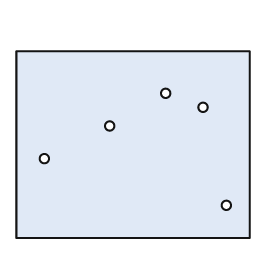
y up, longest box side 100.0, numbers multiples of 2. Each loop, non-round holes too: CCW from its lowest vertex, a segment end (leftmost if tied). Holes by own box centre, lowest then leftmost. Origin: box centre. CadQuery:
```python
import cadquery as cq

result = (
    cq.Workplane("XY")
    .moveTo(-50.0, -40.0)
    .lineTo(50.0, -40.0)
    .lineTo(50.0, 40.0)
    .lineTo(-50.0, 40.0)
    .close()
    .moveTo(40.0, -26.0)
    .circle(2.0)
    .moveTo(-38.0, -6.0)
    .circle(2.0)
    .moveTo(-10.0, 8.0)
    .circle(2.0)
    .moveTo(30.0, 16.0)
    .circle(2.0)
    .moveTo(14.0, 22.0)
    .circle(2.0)
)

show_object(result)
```